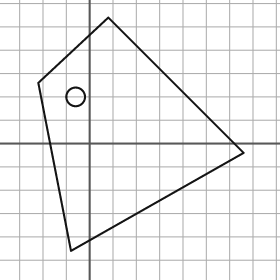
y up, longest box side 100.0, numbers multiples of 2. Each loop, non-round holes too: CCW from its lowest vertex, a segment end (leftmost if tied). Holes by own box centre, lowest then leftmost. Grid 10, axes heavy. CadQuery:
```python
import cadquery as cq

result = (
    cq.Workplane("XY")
    .moveTo(-8.0, -46.0)
    .lineTo(66.0, -4.0)
    .lineTo(8.0, 54.0)
    .lineTo(-22.0, 26.0)
    .close()
    .moveTo(-6.0, 20.0)
    .circle(4.0)
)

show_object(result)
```